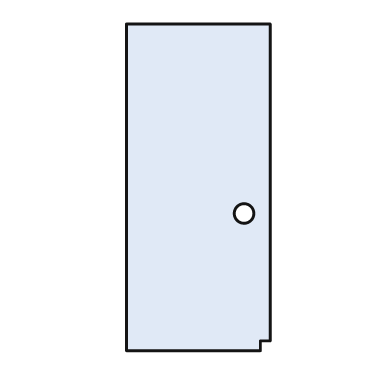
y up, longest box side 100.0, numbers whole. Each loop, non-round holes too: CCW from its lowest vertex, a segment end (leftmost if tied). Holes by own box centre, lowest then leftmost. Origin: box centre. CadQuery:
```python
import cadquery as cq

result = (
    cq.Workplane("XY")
    .moveTo(-22.0, -50.0)
    .lineTo(19.0, -50.0)
    .lineTo(19.0, -47.0)
    .lineTo(22.0, -47.0)
    .lineTo(22.0, 50.0)
    .lineTo(-22.0, 50.0)
    .close()
    .moveTo(14.0, -8.0)
    .circle(3.0)
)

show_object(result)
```